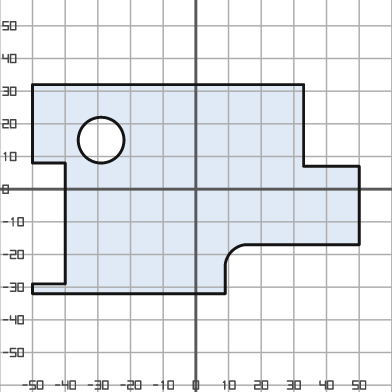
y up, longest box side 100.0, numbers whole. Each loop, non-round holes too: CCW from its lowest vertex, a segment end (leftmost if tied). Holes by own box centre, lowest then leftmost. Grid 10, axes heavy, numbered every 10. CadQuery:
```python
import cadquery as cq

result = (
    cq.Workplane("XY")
    .moveTo(-50.0, -32.0)
    .lineTo(9.0, -32.0)
    .lineTo(9.0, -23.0)
    .threePointArc((11.0, -19.0), (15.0, -17.0))
    .lineTo(50.0, -17.0)
    .lineTo(50.0, 7.0)
    .lineTo(33.0, 7.0)
    .lineTo(33.0, 32.0)
    .lineTo(-50.0, 32.0)
    .lineTo(-50.0, 8.0)
    .lineTo(-40.0, 8.0)
    .lineTo(-40.0, -29.0)
    .lineTo(-50.0, -29.0)
    .close()
    .moveTo(-29.0, 15.0)
    .circle(7.0)
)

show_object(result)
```